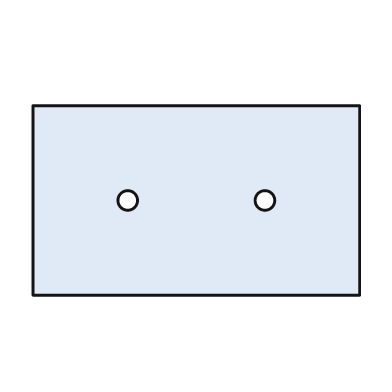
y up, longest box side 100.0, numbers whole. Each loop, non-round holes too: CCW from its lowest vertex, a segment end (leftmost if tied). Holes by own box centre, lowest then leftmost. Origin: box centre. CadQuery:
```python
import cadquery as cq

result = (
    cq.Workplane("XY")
    .moveTo(-50.0, -29.0)
    .lineTo(50.0, -29.0)
    .lineTo(50.0, 29.0)
    .lineTo(-50.0, 29.0)
    .close()
    .moveTo(-21.0, 0.0)
    .circle(3.0)
    .moveTo(21.0, 0.0)
    .circle(3.0)
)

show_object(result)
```